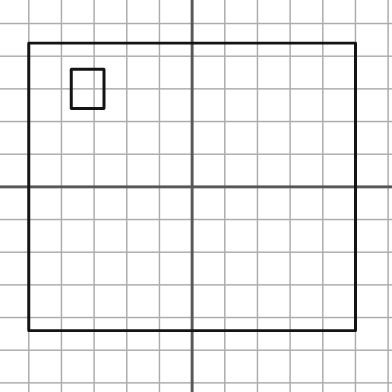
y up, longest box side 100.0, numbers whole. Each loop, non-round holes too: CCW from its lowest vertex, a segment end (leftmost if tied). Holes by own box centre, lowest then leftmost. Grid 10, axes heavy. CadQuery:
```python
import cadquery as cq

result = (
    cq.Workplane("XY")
    .moveTo(-50.0, -44.0)
    .lineTo(50.0, -44.0)
    .lineTo(50.0, 44.0)
    .lineTo(-50.0, 44.0)
    .close()
    .moveTo(-37.0, 24.0)
    .lineTo(-27.0, 24.0)
    .lineTo(-27.0, 36.0)
    .lineTo(-37.0, 36.0)
    .close()
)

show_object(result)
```